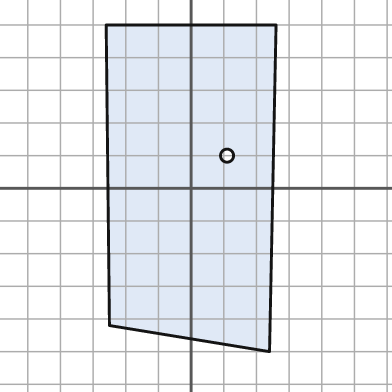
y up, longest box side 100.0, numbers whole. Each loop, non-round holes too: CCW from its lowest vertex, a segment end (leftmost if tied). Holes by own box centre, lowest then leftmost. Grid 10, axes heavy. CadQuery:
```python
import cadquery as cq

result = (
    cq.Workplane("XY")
    .moveTo(24.0, -50.0)
    .lineTo(26.0, 50.0)
    .lineTo(-26.0, 50.0)
    .lineTo(-25.0, -42.0)
    .close()
    .moveTo(11.0, 10.0)
    .circle(2.0)
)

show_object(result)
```